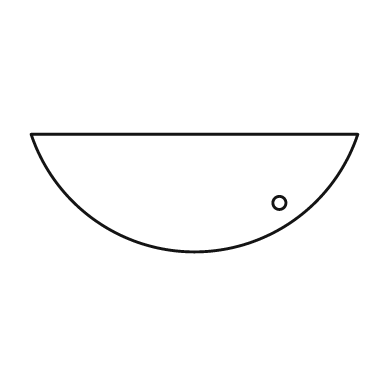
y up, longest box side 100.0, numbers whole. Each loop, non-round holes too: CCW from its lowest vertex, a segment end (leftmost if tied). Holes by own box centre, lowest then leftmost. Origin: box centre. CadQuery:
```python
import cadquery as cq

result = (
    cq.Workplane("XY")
    .moveTo(-50.0, 18.0)
    .threePointArc((0.0, -18.0), (50.0, 18.0))
    .close()
    .moveTo(26.0, -3.0)
    .circle(2.0)
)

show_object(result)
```